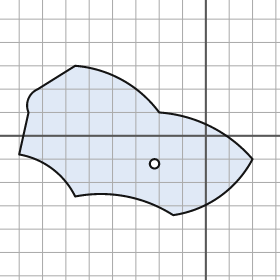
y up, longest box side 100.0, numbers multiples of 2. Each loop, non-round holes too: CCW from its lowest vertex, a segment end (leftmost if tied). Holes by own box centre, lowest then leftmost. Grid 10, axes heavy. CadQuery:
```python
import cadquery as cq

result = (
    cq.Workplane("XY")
    .moveTo(-14.0, -34.0)
    .threePointArc((6.0, -26.0), (20.0, -10.0))
    .threePointArc((2.0, 4.0), (-20.0, 10.0))
    .threePointArc((-36.0, 24.0), (-56.0, 30.0))
    .lineTo(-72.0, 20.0)
    .threePointArc((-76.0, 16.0), (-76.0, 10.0))
    .lineTo(-80.0, -8.0)
    .threePointArc((-66.0, -14.0), (-56.0, -26.0))
    .threePointArc((-34.0, -26.0), (-14.0, -34.0))
    .close()
    .moveTo(-22.0, -12.0)
    .circle(2.0)
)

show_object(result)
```